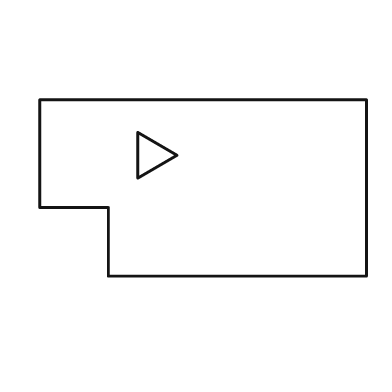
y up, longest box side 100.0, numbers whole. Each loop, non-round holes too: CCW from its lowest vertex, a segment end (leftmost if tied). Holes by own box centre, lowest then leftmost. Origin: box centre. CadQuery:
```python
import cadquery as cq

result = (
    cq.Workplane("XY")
    .moveTo(-29.0, -27.0)
    .lineTo(50.0, -27.0)
    .lineTo(50.0, 27.0)
    .lineTo(-50.0, 27.0)
    .lineTo(-50.0, -6.0)
    .lineTo(-29.0, -6.0)
    .close()
    .moveTo(-20.0, 3.0)
    .lineTo(-8.0, 10.0)
    .lineTo(-20.0, 17.0)
    .close()
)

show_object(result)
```